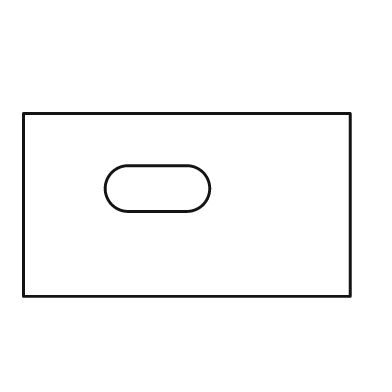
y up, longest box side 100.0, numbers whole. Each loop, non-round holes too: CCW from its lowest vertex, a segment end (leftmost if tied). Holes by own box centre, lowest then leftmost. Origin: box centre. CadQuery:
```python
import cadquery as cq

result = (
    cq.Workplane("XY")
    .moveTo(-50.0, -28.0)
    .lineTo(50.0, -28.0)
    .lineTo(50.0, 28.0)
    .lineTo(-50.0, 28.0)
    .close()
    .moveTo(-18.0, -2.0)
    .lineTo(0.0, -2.0)
    .threePointArc((7.0, 5.0), (0.0, 12.0))
    .lineTo(-18.0, 12.0)
    .threePointArc((-25.0, 5.0), (-18.0, -2.0))
    .close()
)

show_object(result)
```